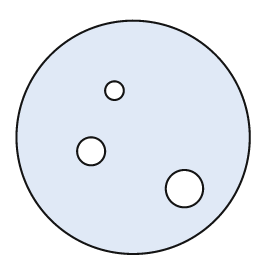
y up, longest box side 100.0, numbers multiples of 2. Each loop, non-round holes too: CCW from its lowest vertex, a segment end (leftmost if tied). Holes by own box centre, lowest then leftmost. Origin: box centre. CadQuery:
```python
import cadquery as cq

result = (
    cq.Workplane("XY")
    .moveTo(0.0, 0.0)
    .circle(50.0)
    .moveTo(22.0, -22.0)
    .circle(8.0)
    .moveTo(-18.0, -6.0)
    .circle(6.0)
    .moveTo(-8.0, 20.0)
    .circle(4.0)
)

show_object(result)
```